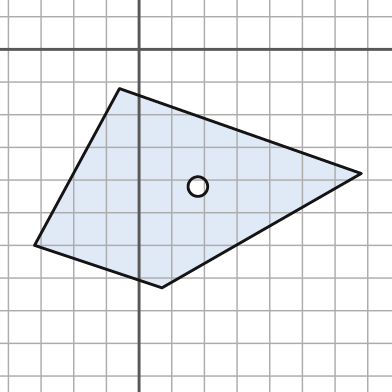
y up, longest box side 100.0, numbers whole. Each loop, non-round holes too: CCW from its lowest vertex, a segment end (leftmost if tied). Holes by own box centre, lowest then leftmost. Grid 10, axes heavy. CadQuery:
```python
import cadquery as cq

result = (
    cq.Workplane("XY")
    .moveTo(7.0, -73.0)
    .lineTo(68.0, -38.0)
    .lineTo(-6.0, -12.0)
    .lineTo(-32.0, -60.0)
    .close()
    .moveTo(18.0, -42.0)
    .circle(3.0)
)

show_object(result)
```